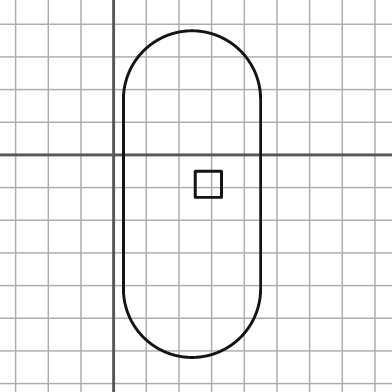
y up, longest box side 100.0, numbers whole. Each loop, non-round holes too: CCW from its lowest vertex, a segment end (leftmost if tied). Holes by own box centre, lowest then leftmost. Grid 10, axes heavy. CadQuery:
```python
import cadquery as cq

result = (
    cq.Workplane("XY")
    .moveTo(3.0, -41.0)
    .threePointArc((24.0, -62.0), (45.0, -41.0))
    .lineTo(45.0, 17.0)
    .threePointArc((24.0, 38.0), (3.0, 17.0))
    .close()
    .moveTo(25.0, -13.0)
    .lineTo(33.0, -13.0)
    .lineTo(33.0, -5.0)
    .lineTo(25.0, -5.0)
    .close()
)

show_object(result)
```